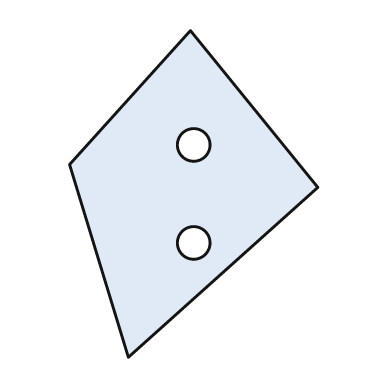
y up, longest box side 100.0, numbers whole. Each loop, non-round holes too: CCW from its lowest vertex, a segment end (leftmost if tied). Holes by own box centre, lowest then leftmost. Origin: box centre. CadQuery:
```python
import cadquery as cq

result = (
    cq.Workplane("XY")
    .moveTo(-20.0, -50.0)
    .lineTo(38.0, 2.0)
    .lineTo(-1.0, 50.0)
    .lineTo(-38.0, 9.0)
    .close()
    .moveTo(0.0, -15.0)
    .circle(5.0)
    .moveTo(0.0, 15.0)
    .circle(5.0)
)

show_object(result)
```